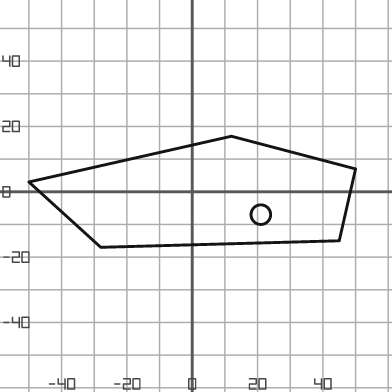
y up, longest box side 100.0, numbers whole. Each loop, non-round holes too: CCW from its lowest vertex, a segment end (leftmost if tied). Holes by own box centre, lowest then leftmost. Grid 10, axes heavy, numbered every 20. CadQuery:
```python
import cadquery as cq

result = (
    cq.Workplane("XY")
    .moveTo(-28.0, -17.0)
    .lineTo(45.0, -15.0)
    .lineTo(50.0, 7.0)
    .lineTo(12.0, 17.0)
    .lineTo(-50.0, 3.0)
    .close()
    .moveTo(21.0, -7.0)
    .circle(3.0)
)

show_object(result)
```